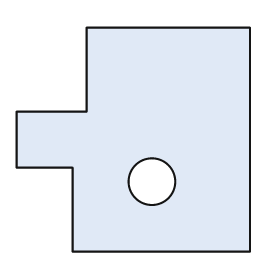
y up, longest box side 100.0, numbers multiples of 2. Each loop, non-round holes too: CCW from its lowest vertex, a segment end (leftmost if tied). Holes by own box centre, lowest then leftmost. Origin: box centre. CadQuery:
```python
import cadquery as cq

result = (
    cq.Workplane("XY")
    .moveTo(-26.0, -48.0)
    .lineTo(50.0, -48.0)
    .lineTo(50.0, 48.0)
    .lineTo(-20.0, 48.0)
    .lineTo(-20.0, 12.0)
    .lineTo(-50.0, 12.0)
    .lineTo(-50.0, -12.0)
    .lineTo(-26.0, -12.0)
    .close()
    .moveTo(8.0, -18.0)
    .circle(10.0)
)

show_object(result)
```